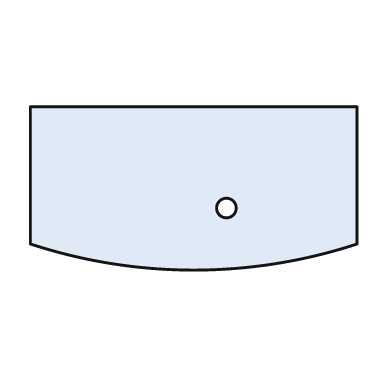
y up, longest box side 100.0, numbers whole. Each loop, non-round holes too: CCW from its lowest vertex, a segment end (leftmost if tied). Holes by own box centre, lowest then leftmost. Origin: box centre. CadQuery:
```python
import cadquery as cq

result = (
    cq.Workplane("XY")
    .moveTo(-50.0, -17.0)
    .threePointArc((0.0, -25.0), (50.0, -17.0))
    .lineTo(50.0, 25.0)
    .lineTo(-50.0, 25.0)
    .close()
    .moveTo(10.0, -6.0)
    .circle(3.0)
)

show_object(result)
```